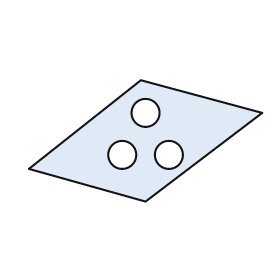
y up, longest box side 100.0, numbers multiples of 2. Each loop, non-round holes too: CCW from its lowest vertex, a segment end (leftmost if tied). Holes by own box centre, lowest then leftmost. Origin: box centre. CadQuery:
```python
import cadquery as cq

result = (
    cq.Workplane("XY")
    .moveTo(0.0, -26.0)
    .lineTo(50.0, 12.0)
    .lineTo(-2.0, 26.0)
    .lineTo(-50.0, -12.0)
    .close()
    .moveTo(-10.0, -6.0)
    .circle(6.0)
    .moveTo(10.0, -6.0)
    .circle(6.0)
    .moveTo(0.0, 12.0)
    .circle(6.0)
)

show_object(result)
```